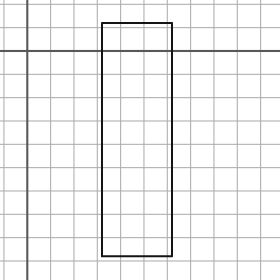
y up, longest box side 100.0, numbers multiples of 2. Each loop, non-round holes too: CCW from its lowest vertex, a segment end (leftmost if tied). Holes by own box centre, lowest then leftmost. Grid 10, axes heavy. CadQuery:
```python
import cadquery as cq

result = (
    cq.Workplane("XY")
    .moveTo(32.0, -88.0)
    .lineTo(62.0, -88.0)
    .lineTo(62.0, 12.0)
    .lineTo(32.0, 12.0)
    .close()
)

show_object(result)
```